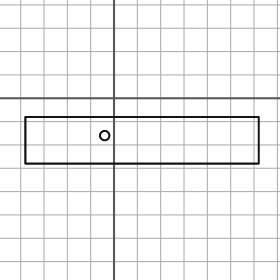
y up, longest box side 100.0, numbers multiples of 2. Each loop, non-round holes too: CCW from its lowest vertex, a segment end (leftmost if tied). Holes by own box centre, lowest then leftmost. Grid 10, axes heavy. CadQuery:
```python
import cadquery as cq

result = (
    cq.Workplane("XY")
    .moveTo(-38.0, -28.0)
    .lineTo(62.0, -28.0)
    .lineTo(62.0, -8.0)
    .lineTo(-38.0, -8.0)
    .close()
    .moveTo(-4.0, -16.0)
    .circle(2.0)
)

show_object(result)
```